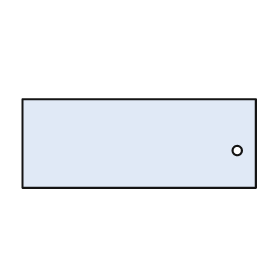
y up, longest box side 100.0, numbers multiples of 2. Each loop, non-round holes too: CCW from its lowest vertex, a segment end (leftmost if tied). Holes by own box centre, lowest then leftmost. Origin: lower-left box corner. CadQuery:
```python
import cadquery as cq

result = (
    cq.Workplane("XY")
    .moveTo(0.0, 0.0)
    .lineTo(100.0, 0.0)
    .lineTo(100.0, 38.0)
    .lineTo(0.0, 38.0)
    .close()
    .moveTo(92.0, 16.0)
    .circle(2.0)
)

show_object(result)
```